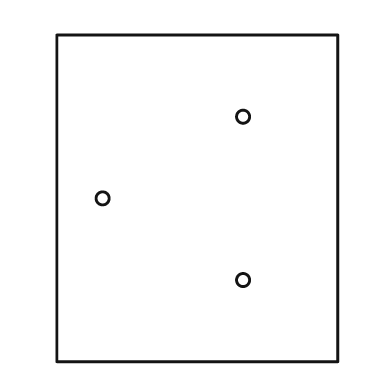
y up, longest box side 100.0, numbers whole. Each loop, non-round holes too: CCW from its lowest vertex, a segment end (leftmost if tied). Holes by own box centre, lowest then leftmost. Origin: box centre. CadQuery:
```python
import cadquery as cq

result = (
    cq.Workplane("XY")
    .moveTo(-43.0, -50.0)
    .lineTo(43.0, -50.0)
    .lineTo(43.0, 50.0)
    .lineTo(-43.0, 50.0)
    .close()
    .moveTo(14.0, -25.0)
    .circle(2.0)
    .moveTo(-29.0, 0.0)
    .circle(2.0)
    .moveTo(14.0, 25.0)
    .circle(2.0)
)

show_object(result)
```